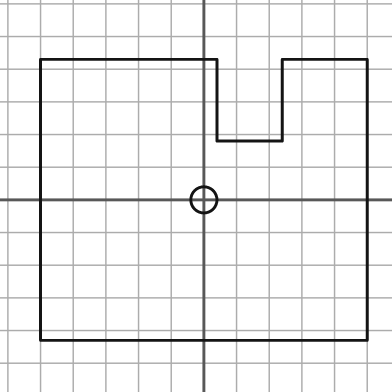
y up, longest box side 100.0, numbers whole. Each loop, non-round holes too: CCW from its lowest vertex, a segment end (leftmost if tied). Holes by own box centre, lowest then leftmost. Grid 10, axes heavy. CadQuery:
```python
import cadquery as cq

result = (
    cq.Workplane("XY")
    .moveTo(-50.0, -43.0)
    .lineTo(50.0, -43.0)
    .lineTo(50.0, 43.0)
    .lineTo(24.0, 43.0)
    .lineTo(24.0, 18.0)
    .lineTo(4.0, 18.0)
    .lineTo(4.0, 43.0)
    .lineTo(-50.0, 43.0)
    .close()
    .moveTo(0.0, 0.0)
    .circle(4.0)
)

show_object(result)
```